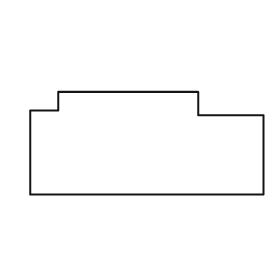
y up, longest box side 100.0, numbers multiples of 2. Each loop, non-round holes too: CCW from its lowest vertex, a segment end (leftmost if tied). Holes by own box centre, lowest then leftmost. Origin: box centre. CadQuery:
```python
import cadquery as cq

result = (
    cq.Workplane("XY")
    .moveTo(-50.0, -22.0)
    .lineTo(50.0, -22.0)
    .lineTo(50.0, 12.0)
    .lineTo(22.0, 12.0)
    .lineTo(22.0, 22.0)
    .lineTo(-38.0, 22.0)
    .lineTo(-38.0, 14.0)
    .lineTo(-50.0, 14.0)
    .close()
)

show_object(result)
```